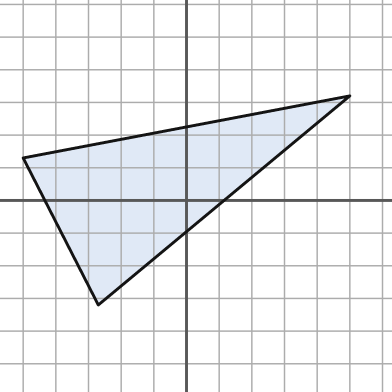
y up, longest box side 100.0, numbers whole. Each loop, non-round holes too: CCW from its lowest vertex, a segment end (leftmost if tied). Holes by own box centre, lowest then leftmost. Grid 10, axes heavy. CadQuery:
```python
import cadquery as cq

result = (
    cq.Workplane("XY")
    .moveTo(-27.0, -32.0)
    .lineTo(50.0, 32.0)
    .lineTo(-50.0, 13.0)
    .close()
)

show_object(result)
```